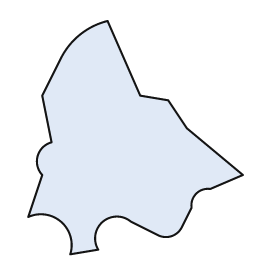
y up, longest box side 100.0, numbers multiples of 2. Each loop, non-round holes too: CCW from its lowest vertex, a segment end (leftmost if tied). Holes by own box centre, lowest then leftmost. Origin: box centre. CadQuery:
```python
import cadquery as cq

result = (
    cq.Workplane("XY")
    .moveTo(-28.0, -50.0)
    .lineTo(-16.0, -48.0)
    .threePointArc((-14.0, -36.0), (-2.0, -36.0))
    .lineTo(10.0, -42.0)
    .threePointArc((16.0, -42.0), (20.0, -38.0))
    .lineTo(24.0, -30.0)
    .threePointArc((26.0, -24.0), (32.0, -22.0))
    .lineTo(46.0, -16.0)
    .lineTo(22.0, 4.0)
    .lineTo(14.0, 16.0)
    .lineTo(2.0, 18.0)
    .lineTo(-12.0, 50.0)
    .threePointArc((-24.0, 44.0), (-32.0, 34.0))
    .lineTo(-40.0, 18.0)
    .lineTo(-36.0, -2.0)
    .threePointArc((-42.0, -8.0), (-40.0, -16.0))
    .lineTo(-46.0, -34.0)
    .threePointArc((-32.0, -36.0), (-28.0, -50.0))
    .close()
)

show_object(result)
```